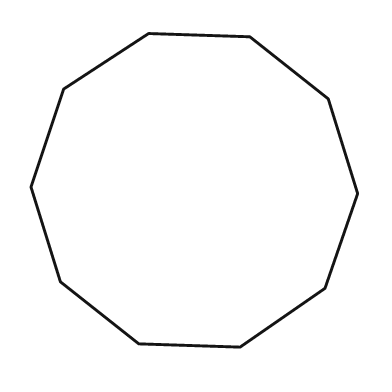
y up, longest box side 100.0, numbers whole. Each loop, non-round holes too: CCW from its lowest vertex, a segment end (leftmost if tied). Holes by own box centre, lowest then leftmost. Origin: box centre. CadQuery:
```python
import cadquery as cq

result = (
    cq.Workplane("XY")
    .moveTo(14.0, -48.0)
    .lineTo(40.0, -30.0)
    .lineTo(50.0, -1.0)
    .lineTo(41.0, 28.0)
    .lineTo(17.0, 47.0)
    .lineTo(-14.0, 48.0)
    .lineTo(-40.0, 31.0)
    .lineTo(-50.0, 1.0)
    .lineTo(-41.0, -28.0)
    .lineTo(-17.0, -47.0)
    .close()
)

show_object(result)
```